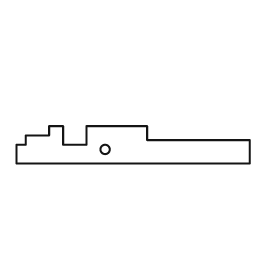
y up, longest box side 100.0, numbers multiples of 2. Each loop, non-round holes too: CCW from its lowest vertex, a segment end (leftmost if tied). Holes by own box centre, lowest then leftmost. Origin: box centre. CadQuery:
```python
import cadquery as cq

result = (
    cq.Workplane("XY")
    .moveTo(-50.0, -8.0)
    .lineTo(50.0, -8.0)
    .lineTo(50.0, 2.0)
    .lineTo(6.0, 2.0)
    .lineTo(6.0, 8.0)
    .lineTo(-20.0, 8.0)
    .lineTo(-20.0, 0.0)
    .lineTo(-30.0, 0.0)
    .lineTo(-30.0, 8.0)
    .lineTo(-36.0, 8.0)
    .lineTo(-36.0, 4.0)
    .lineTo(-46.0, 4.0)
    .lineTo(-46.0, 0.0)
    .lineTo(-50.0, 0.0)
    .close()
    .moveTo(-12.0, -2.0)
    .circle(2.0)
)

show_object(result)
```